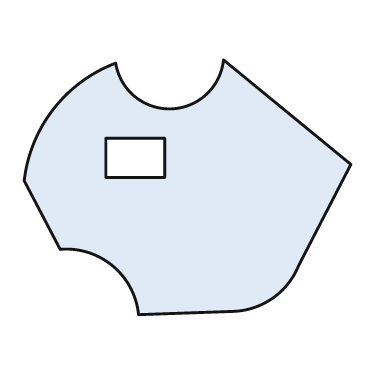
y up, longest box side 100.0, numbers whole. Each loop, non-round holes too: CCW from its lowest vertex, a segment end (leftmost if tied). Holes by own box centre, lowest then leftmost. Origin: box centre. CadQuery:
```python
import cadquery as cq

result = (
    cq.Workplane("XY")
    .moveTo(-15.0, -39.0)
    .lineTo(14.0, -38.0)
    .threePointArc((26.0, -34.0), (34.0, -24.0))
    .lineTo(50.0, 7.0)
    .lineTo(11.0, 39.0)
    .threePointArc((-5.0, 24.0), (-22.0, 38.0))
    .threePointArc((-41.0, 24.0), (-50.0, 2.0))
    .lineTo(-39.0, -19.0)
    .threePointArc((-23.0, -24.0), (-15.0, -39.0))
    .close()
    .moveTo(-25.0, 3.0)
    .lineTo(-7.0, 3.0)
    .lineTo(-7.0, 15.0)
    .lineTo(-25.0, 15.0)
    .close()
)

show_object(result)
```